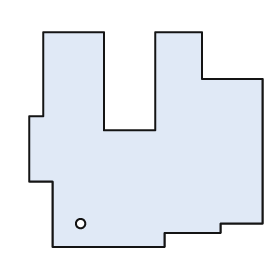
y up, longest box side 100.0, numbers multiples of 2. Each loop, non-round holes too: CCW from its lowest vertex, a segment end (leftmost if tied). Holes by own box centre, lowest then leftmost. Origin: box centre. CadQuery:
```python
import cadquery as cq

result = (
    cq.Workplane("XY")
    .moveTo(-40.0, -46.0)
    .lineTo(8.0, -46.0)
    .lineTo(8.0, -40.0)
    .lineTo(32.0, -40.0)
    .lineTo(32.0, -36.0)
    .lineTo(50.0, -36.0)
    .lineTo(50.0, 26.0)
    .lineTo(24.0, 26.0)
    .lineTo(24.0, 46.0)
    .lineTo(4.0, 46.0)
    .lineTo(4.0, 4.0)
    .lineTo(-18.0, 4.0)
    .lineTo(-18.0, 46.0)
    .lineTo(-44.0, 46.0)
    .lineTo(-44.0, 10.0)
    .lineTo(-50.0, 10.0)
    .lineTo(-50.0, -18.0)
    .lineTo(-40.0, -18.0)
    .close()
    .moveTo(-28.0, -36.0)
    .circle(2.0)
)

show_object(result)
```